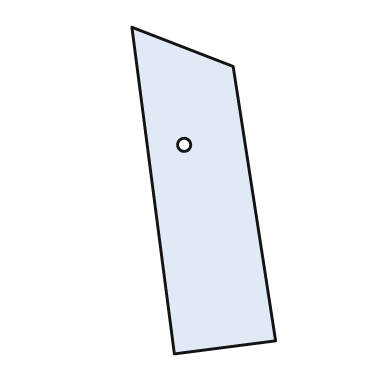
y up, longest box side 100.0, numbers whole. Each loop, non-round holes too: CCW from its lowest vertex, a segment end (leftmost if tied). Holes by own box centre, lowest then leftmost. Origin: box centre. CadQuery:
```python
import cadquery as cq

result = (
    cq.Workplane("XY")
    .moveTo(-9.0, -50.0)
    .lineTo(22.0, -46.0)
    .lineTo(9.0, 38.0)
    .lineTo(-22.0, 50.0)
    .close()
    .moveTo(-6.0, 14.0)
    .circle(2.0)
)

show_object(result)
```